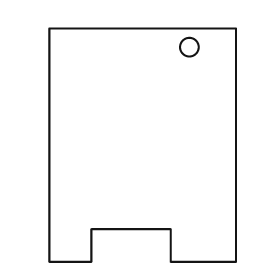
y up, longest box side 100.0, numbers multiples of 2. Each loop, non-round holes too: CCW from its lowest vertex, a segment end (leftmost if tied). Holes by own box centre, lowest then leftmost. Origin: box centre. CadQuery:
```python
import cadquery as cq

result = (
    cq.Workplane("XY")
    .moveTo(-40.0, -50.0)
    .lineTo(-22.0, -50.0)
    .lineTo(-22.0, -36.0)
    .lineTo(12.0, -36.0)
    .lineTo(12.0, -50.0)
    .lineTo(40.0, -50.0)
    .lineTo(40.0, 50.0)
    .lineTo(-40.0, 50.0)
    .close()
    .moveTo(20.0, 42.0)
    .circle(4.0)
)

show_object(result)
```